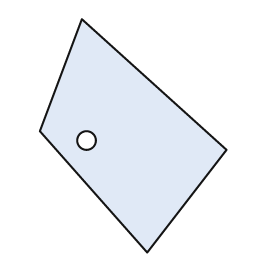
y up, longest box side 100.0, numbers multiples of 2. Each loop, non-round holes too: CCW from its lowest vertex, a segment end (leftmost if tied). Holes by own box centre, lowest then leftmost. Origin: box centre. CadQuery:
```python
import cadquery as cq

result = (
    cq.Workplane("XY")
    .moveTo(6.0, -50.0)
    .lineTo(40.0, -6.0)
    .lineTo(-22.0, 50.0)
    .lineTo(-40.0, 2.0)
    .close()
    .moveTo(-20.0, -2.0)
    .circle(4.0)
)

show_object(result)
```